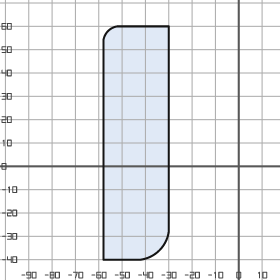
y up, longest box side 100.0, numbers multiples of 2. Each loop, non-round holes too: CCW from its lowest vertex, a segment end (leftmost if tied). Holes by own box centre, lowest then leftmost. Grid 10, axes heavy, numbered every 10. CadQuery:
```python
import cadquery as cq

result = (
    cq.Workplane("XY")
    .moveTo(-58.0, -40.0)
    .lineTo(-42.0, -40.0)
    .threePointArc((-34.0, -36.0), (-30.0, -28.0))
    .lineTo(-30.0, 60.0)
    .lineTo(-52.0, 60.0)
    .threePointArc((-56.0, 58.0), (-58.0, 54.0))
    .close()
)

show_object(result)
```